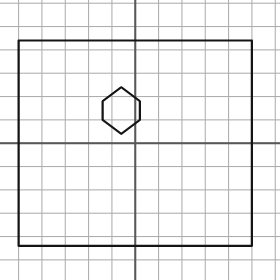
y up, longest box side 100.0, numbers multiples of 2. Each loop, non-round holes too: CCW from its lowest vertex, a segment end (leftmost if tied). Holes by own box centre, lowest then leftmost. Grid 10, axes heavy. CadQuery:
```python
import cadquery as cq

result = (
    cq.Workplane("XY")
    .moveTo(-50.0, -44.0)
    .lineTo(50.0, -44.0)
    .lineTo(50.0, 44.0)
    .lineTo(-50.0, 44.0)
    .close()
    .moveTo(-6.0, 4.0)
    .lineTo(2.0, 10.0)
    .lineTo(2.0, 18.0)
    .lineTo(-6.0, 24.0)
    .lineTo(-14.0, 18.0)
    .lineTo(-14.0, 10.0)
    .close()
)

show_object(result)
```